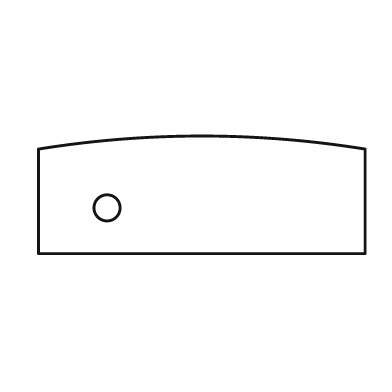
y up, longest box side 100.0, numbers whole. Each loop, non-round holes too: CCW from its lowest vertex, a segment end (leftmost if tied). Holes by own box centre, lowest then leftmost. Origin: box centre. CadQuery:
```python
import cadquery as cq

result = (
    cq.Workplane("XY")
    .moveTo(-50.0, -18.0)
    .lineTo(50.0, -18.0)
    .lineTo(50.0, 14.0)
    .threePointArc((0.0, 18.0), (-50.0, 14.0))
    .close()
    .moveTo(-29.0, -4.0)
    .circle(4.0)
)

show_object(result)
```